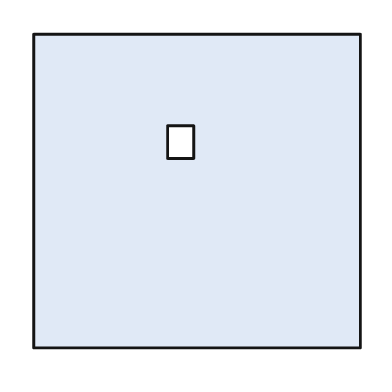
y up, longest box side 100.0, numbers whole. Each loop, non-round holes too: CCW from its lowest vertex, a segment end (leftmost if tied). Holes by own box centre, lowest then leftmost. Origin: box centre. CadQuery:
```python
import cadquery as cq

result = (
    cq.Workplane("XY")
    .moveTo(-50.0, -48.0)
    .lineTo(50.0, -48.0)
    .lineTo(50.0, 48.0)
    .lineTo(-50.0, 48.0)
    .close()
    .moveTo(-9.0, 10.0)
    .lineTo(-1.0, 10.0)
    .lineTo(-1.0, 20.0)
    .lineTo(-9.0, 20.0)
    .close()
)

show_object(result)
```